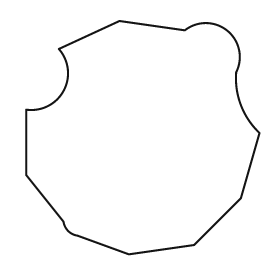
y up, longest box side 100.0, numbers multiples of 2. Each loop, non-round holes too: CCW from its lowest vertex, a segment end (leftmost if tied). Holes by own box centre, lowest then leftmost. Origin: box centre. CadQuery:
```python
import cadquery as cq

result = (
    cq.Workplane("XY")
    .moveTo(-6.0, -50.0)
    .lineTo(22.0, -46.0)
    .lineTo(42.0, -26.0)
    .lineTo(50.0, 2.0)
    .threePointArc((42.0, 14.0), (40.0, 28.0))
    .threePointArc((36.0, 46.0), (18.0, 46.0))
    .lineTo(-10.0, 50.0)
    .lineTo(-36.0, 38.0)
    .threePointArc((-34.0, 20.0), (-50.0, 12.0))
    .lineTo(-50.0, -16.0)
    .lineTo(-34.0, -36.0)
    .threePointArc((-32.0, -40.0), (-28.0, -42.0))
    .close()
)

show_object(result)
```